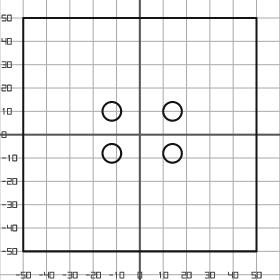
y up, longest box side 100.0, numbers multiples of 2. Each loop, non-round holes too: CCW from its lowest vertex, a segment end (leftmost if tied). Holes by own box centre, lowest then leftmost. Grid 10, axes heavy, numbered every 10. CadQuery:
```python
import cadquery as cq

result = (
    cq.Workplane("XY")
    .moveTo(-50.0, -50.0)
    .lineTo(50.0, -50.0)
    .lineTo(50.0, 50.0)
    .lineTo(-50.0, 50.0)
    .close()
    .moveTo(-12.0, -8.0)
    .circle(4.0)
    .moveTo(14.0, -8.0)
    .circle(4.0)
    .moveTo(-12.0, 10.0)
    .circle(4.0)
    .moveTo(14.0, 10.0)
    .circle(4.0)
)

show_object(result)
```